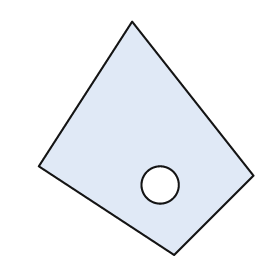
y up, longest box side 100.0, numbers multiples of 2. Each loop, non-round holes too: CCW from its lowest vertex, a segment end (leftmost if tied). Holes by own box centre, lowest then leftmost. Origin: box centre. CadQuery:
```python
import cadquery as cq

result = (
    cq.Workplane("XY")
    .moveTo(12.0, -50.0)
    .lineTo(46.0, -16.0)
    .lineTo(-6.0, 50.0)
    .lineTo(-46.0, -12.0)
    .close()
    .moveTo(6.0, -20.0)
    .circle(8.0)
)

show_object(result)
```